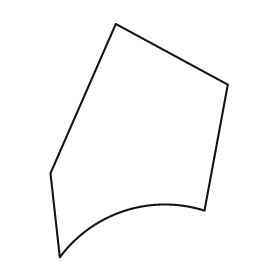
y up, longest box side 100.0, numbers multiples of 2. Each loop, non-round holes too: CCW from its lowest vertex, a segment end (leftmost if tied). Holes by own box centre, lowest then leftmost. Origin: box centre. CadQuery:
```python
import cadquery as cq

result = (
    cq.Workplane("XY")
    .moveTo(-34.0, -50.0)
    .threePointArc((-6.0, -30.0), (28.0, -30.0))
    .lineTo(38.0, 24.0)
    .lineTo(-10.0, 50.0)
    .lineTo(-38.0, -14.0)
    .close()
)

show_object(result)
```